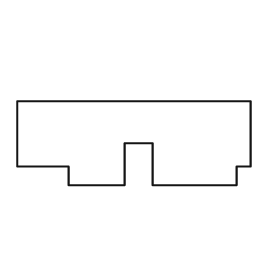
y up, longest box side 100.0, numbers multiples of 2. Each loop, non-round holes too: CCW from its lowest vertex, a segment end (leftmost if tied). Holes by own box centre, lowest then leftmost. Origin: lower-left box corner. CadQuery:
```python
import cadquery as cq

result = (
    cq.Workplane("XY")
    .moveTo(22.0, 0.0)
    .lineTo(46.0, 0.0)
    .lineTo(46.0, 18.0)
    .lineTo(58.0, 18.0)
    .lineTo(58.0, 0.0)
    .lineTo(94.0, 0.0)
    .lineTo(94.0, 8.0)
    .lineTo(100.0, 8.0)
    .lineTo(100.0, 36.0)
    .lineTo(0.0, 36.0)
    .lineTo(0.0, 8.0)
    .lineTo(22.0, 8.0)
    .close()
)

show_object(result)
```